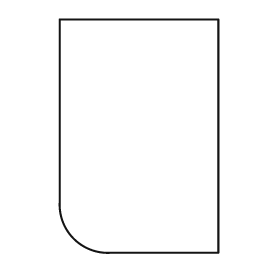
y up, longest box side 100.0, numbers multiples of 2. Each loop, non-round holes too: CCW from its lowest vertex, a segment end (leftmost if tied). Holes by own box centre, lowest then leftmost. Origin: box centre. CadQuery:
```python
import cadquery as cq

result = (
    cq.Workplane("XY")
    .moveTo(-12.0, -50.0)
    .lineTo(34.0, -50.0)
    .lineTo(34.0, 50.0)
    .lineTo(-34.0, 50.0)
    .lineTo(-34.0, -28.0)
    .threePointArc((-28.0, -44.0), (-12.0, -50.0))
    .close()
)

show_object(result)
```